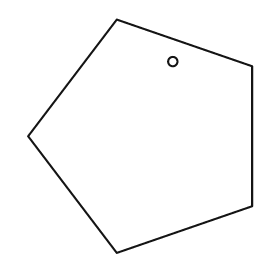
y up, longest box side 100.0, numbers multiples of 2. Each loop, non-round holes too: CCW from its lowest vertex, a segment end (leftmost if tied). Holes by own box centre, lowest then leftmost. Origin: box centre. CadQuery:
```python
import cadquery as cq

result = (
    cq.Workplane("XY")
    .moveTo(-10.0, -50.0)
    .lineTo(48.0, -30.0)
    .lineTo(48.0, 30.0)
    .lineTo(-10.0, 50.0)
    .lineTo(-48.0, 0.0)
    .close()
    .moveTo(14.0, 32.0)
    .circle(2.0)
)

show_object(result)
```